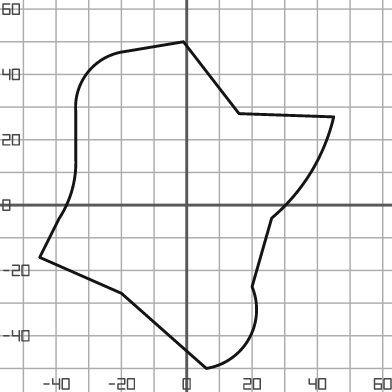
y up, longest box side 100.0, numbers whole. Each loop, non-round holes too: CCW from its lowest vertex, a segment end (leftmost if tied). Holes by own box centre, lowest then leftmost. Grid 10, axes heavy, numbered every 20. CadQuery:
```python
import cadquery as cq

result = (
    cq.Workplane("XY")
    .moveTo(6.0, -50.0)
    .threePointArc((19.0, -41.0), (20.0, -25.0))
    .lineTo(26.0, -4.0)
    .threePointArc((38.0, 10.0), (45.0, 27.0))
    .lineTo(16.0, 28.0)
    .lineTo(-1.0, 50.0)
    .lineTo(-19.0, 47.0)
    .threePointArc((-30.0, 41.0), (-34.0, 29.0))
    .lineTo(-34.0, 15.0)
    .threePointArc((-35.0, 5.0), (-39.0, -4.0))
    .lineTo(-45.0, -16.0)
    .lineTo(-20.0, -27.0)
    .close()
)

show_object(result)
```